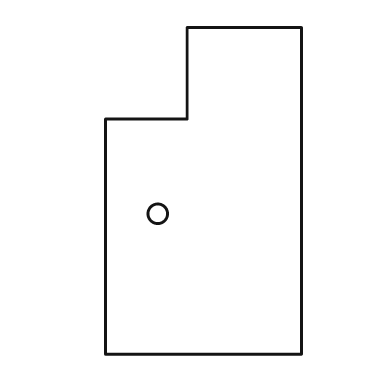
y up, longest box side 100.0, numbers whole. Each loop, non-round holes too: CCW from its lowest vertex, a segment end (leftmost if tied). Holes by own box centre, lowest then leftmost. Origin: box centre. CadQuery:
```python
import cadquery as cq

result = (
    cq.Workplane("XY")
    .moveTo(-30.0, -50.0)
    .lineTo(30.0, -50.0)
    .lineTo(30.0, 50.0)
    .lineTo(-5.0, 50.0)
    .lineTo(-5.0, 22.0)
    .lineTo(-30.0, 22.0)
    .close()
    .moveTo(-14.0, -7.0)
    .circle(3.0)
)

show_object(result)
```